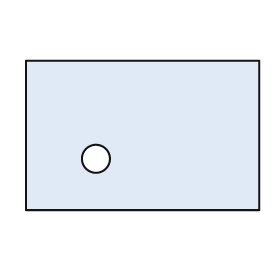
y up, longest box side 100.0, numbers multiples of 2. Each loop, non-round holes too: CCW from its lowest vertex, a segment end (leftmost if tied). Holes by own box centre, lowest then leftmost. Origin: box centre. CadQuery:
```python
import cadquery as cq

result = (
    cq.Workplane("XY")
    .moveTo(-50.0, -32.0)
    .lineTo(50.0, -32.0)
    .lineTo(50.0, 32.0)
    .lineTo(-50.0, 32.0)
    .close()
    .moveTo(-20.0, -10.0)
    .circle(6.0)
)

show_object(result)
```